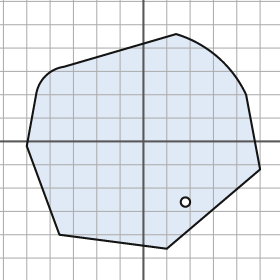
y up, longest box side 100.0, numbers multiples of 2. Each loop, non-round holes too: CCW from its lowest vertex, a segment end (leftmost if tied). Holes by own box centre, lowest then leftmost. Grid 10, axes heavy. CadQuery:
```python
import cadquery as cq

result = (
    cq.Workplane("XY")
    .moveTo(10.0, -46.0)
    .lineTo(50.0, -12.0)
    .lineTo(44.0, 20.0)
    .threePointArc((32.0, 36.0), (14.0, 46.0))
    .lineTo(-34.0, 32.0)
    .threePointArc((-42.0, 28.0), (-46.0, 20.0))
    .lineTo(-50.0, -2.0)
    .lineTo(-36.0, -40.0)
    .close()
    .moveTo(18.0, -26.0)
    .circle(2.0)
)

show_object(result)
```